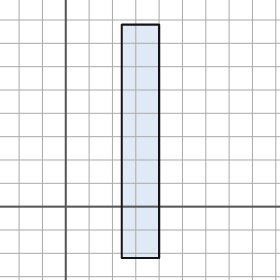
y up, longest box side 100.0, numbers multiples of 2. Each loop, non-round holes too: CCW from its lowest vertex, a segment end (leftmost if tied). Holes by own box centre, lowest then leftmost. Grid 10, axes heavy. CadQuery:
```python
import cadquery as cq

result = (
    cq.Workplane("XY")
    .moveTo(24.0, -22.0)
    .lineTo(40.0, -22.0)
    .lineTo(40.0, 78.0)
    .lineTo(24.0, 78.0)
    .close()
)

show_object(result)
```